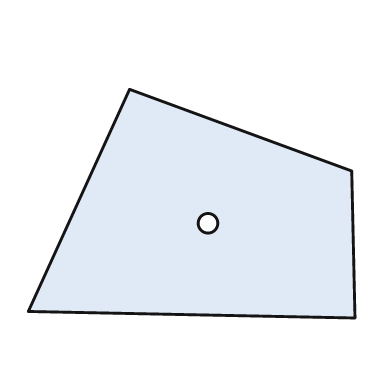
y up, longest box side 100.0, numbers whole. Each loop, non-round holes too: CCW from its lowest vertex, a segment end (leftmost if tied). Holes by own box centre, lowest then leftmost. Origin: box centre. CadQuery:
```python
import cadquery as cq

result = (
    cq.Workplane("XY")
    .moveTo(50.0, -35.0)
    .lineTo(49.0, 10.0)
    .lineTo(-19.0, 35.0)
    .lineTo(-50.0, -33.0)
    .close()
    .moveTo(5.0, -6.0)
    .circle(3.0)
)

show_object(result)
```